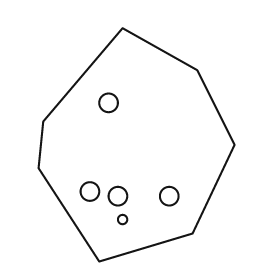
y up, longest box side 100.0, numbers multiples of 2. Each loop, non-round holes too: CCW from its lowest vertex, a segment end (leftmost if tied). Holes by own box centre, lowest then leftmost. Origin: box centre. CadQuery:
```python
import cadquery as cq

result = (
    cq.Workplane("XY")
    .moveTo(-16.0, -50.0)
    .lineTo(24.0, -38.0)
    .lineTo(42.0, 0.0)
    .lineTo(26.0, 32.0)
    .lineTo(-6.0, 50.0)
    .lineTo(-40.0, 10.0)
    .lineTo(-42.0, -10.0)
    .close()
    .moveTo(-6.0, -32.0)
    .circle(2.0)
    .moveTo(-8.0, -22.0)
    .circle(4.0)
    .moveTo(14.0, -22.0)
    .circle(4.0)
    .moveTo(-20.0, -20.0)
    .circle(4.0)
    .moveTo(-12.0, 18.0)
    .circle(4.0)
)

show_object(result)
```